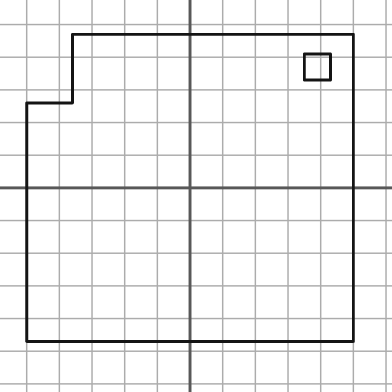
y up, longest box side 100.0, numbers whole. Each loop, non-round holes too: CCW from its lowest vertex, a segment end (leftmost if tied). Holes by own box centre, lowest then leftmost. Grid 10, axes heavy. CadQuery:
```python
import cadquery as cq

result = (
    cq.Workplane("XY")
    .moveTo(-50.0, -47.0)
    .lineTo(50.0, -47.0)
    .lineTo(50.0, 47.0)
    .lineTo(-36.0, 47.0)
    .lineTo(-36.0, 26.0)
    .lineTo(-50.0, 26.0)
    .close()
    .moveTo(35.0, 33.0)
    .lineTo(43.0, 33.0)
    .lineTo(43.0, 41.0)
    .lineTo(35.0, 41.0)
    .close()
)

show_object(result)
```